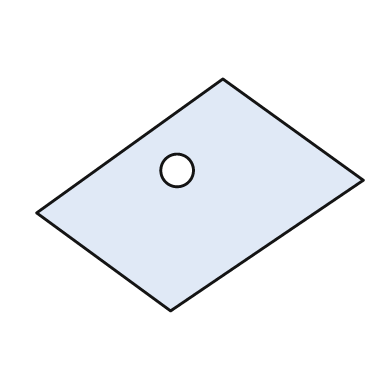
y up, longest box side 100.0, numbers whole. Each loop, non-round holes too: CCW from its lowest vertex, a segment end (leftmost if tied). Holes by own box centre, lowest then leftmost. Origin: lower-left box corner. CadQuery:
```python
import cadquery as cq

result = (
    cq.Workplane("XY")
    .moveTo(41.0, 0.0)
    .lineTo(100.0, 40.0)
    .lineTo(57.0, 71.0)
    .lineTo(0.0, 30.0)
    .close()
    .moveTo(43.0, 43.0)
    .circle(5.0)
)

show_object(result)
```